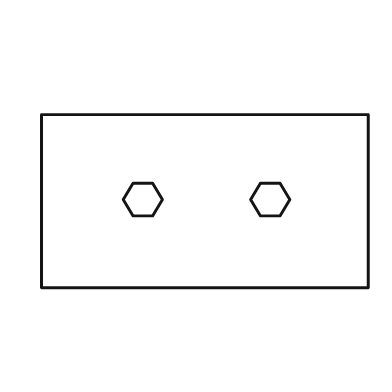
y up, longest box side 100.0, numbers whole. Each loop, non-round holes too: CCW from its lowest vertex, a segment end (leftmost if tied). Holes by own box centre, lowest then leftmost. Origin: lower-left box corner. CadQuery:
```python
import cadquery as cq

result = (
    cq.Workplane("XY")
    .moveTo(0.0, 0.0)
    .lineTo(100.0, 0.0)
    .lineTo(100.0, 53.0)
    .lineTo(0.0, 53.0)
    .close()
    .moveTo(28.0, 22.0)
    .lineTo(34.0, 22.0)
    .lineTo(37.0, 27.0)
    .lineTo(34.0, 32.0)
    .lineTo(28.0, 32.0)
    .lineTo(25.0, 27.0)
    .close()
    .moveTo(67.0, 22.0)
    .lineTo(73.0, 22.0)
    .lineTo(76.0, 27.0)
    .lineTo(73.0, 32.0)
    .lineTo(67.0, 32.0)
    .lineTo(64.0, 27.0)
    .close()
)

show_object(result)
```